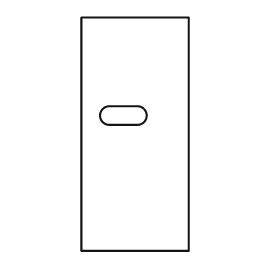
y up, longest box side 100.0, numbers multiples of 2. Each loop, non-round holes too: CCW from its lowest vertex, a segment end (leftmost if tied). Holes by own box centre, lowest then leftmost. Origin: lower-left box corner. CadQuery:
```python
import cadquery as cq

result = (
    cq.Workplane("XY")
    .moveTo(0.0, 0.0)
    .lineTo(46.0, 0.0)
    .lineTo(46.0, 100.0)
    .lineTo(0.0, 100.0)
    .close()
    .moveTo(12.0, 54.0)
    .lineTo(24.0, 54.0)
    .threePointArc((28.0, 58.0), (24.0, 62.0))
    .lineTo(12.0, 62.0)
    .threePointArc((8.0, 58.0), (12.0, 54.0))
    .close()
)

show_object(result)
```